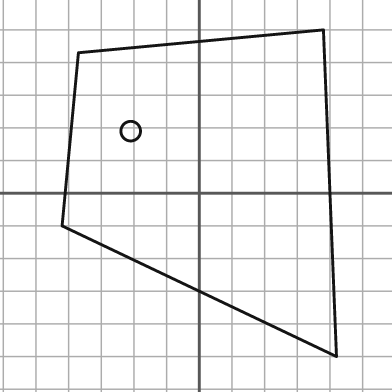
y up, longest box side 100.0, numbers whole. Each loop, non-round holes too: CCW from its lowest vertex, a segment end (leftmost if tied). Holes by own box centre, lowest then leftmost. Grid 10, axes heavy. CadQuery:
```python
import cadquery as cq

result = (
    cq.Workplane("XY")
    .moveTo(42.0, -50.0)
    .lineTo(38.0, 50.0)
    .lineTo(-37.0, 43.0)
    .lineTo(-42.0, -10.0)
    .close()
    .moveTo(-21.0, 19.0)
    .circle(3.0)
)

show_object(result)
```